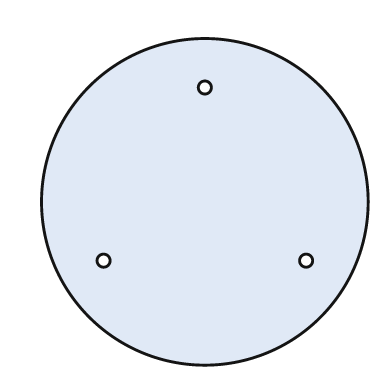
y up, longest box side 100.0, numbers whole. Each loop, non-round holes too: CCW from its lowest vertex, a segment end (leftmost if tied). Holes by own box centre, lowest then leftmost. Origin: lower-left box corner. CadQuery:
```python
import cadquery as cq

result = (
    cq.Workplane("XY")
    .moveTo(50.0, 50.0)
    .circle(50.0)
    .moveTo(19.0, 32.0)
    .circle(2.0)
    .moveTo(81.0, 32.0)
    .circle(2.0)
    .moveTo(50.0, 85.0)
    .circle(2.0)
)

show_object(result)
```